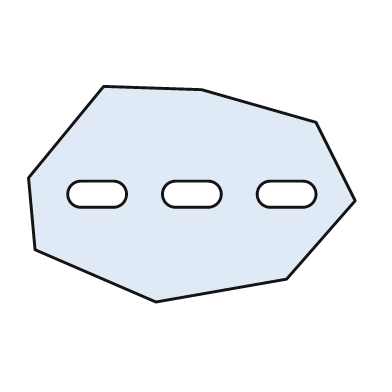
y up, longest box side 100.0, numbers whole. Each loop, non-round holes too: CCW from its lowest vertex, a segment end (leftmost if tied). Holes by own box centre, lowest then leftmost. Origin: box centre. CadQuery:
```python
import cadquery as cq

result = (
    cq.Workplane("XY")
    .moveTo(-11.0, -33.0)
    .lineTo(29.0, -26.0)
    .lineTo(50.0, -2.0)
    .lineTo(38.0, 22.0)
    .lineTo(3.0, 32.0)
    .lineTo(-27.0, 33.0)
    .lineTo(-50.0, 5.0)
    .lineTo(-48.0, -17.0)
    .close()
    .moveTo(-34.0, -4.0)
    .lineTo(-24.0, -4.0)
    .threePointArc((-20.0, 0.0), (-24.0, 4.0))
    .lineTo(-34.0, 4.0)
    .threePointArc((-38.0, 0.0), (-34.0, -4.0))
    .close()
    .moveTo(-5.0, -4.0)
    .lineTo(5.0, -4.0)
    .threePointArc((9.0, 0.0), (5.0, 4.0))
    .lineTo(-5.0, 4.0)
    .threePointArc((-9.0, 0.0), (-5.0, -4.0))
    .close()
    .moveTo(24.0, -4.0)
    .lineTo(34.0, -4.0)
    .threePointArc((38.0, 0.0), (34.0, 4.0))
    .lineTo(24.0, 4.0)
    .threePointArc((20.0, 0.0), (24.0, -4.0))
    .close()
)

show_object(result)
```